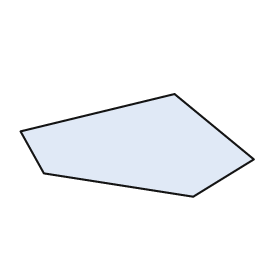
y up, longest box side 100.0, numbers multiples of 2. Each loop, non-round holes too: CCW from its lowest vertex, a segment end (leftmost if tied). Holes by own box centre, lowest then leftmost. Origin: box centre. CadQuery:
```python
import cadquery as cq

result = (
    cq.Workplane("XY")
    .moveTo(24.0, -22.0)
    .lineTo(50.0, -6.0)
    .lineTo(16.0, 22.0)
    .lineTo(-50.0, 6.0)
    .lineTo(-40.0, -12.0)
    .close()
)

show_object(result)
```